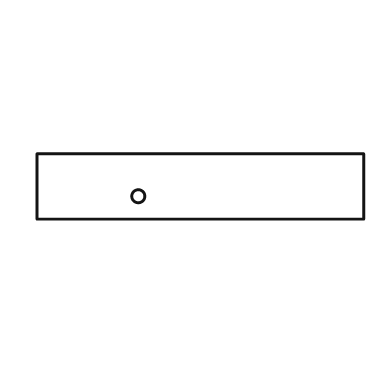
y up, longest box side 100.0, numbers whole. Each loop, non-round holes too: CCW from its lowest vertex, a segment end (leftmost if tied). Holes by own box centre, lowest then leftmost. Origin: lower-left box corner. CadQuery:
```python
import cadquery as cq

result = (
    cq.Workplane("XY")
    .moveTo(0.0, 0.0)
    .lineTo(100.0, 0.0)
    .lineTo(100.0, 20.0)
    .lineTo(0.0, 20.0)
    .close()
    .moveTo(31.0, 7.0)
    .circle(2.0)
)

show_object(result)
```